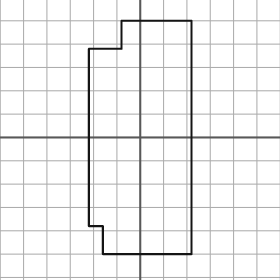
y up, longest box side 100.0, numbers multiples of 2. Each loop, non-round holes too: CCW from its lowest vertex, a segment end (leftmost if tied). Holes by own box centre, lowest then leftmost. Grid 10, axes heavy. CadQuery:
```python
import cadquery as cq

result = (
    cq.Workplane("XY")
    .moveTo(-16.0, -50.0)
    .lineTo(22.0, -50.0)
    .lineTo(22.0, 50.0)
    .lineTo(-8.0, 50.0)
    .lineTo(-8.0, 38.0)
    .lineTo(-22.0, 38.0)
    .lineTo(-22.0, -38.0)
    .lineTo(-16.0, -38.0)
    .close()
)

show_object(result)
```